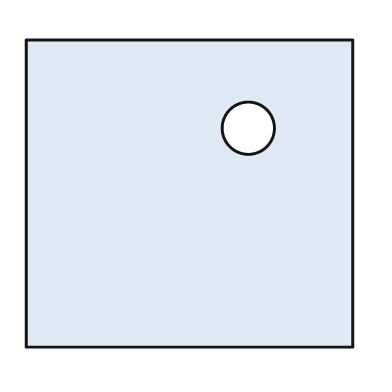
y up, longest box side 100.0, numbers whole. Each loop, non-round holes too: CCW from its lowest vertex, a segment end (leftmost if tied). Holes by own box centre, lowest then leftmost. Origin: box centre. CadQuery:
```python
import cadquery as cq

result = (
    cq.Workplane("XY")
    .moveTo(-50.0, -47.0)
    .lineTo(50.0, -47.0)
    .lineTo(50.0, 47.0)
    .lineTo(-50.0, 47.0)
    .close()
    .moveTo(18.0, 20.0)
    .circle(8.0)
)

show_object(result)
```